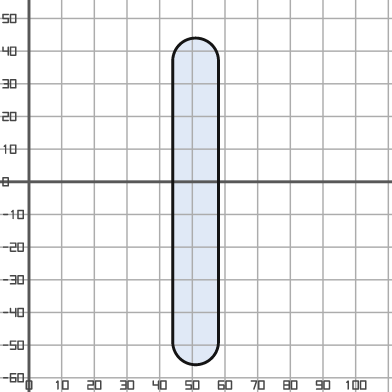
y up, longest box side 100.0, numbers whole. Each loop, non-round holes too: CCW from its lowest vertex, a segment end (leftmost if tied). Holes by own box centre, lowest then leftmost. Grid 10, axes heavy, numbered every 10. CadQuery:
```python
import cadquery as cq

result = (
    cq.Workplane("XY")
    .moveTo(44.0, -49.0)
    .threePointArc((51.0, -56.0), (58.0, -49.0))
    .lineTo(58.0, 37.0)
    .threePointArc((51.0, 44.0), (44.0, 37.0))
    .close()
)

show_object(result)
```